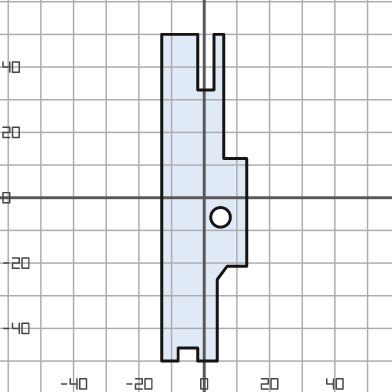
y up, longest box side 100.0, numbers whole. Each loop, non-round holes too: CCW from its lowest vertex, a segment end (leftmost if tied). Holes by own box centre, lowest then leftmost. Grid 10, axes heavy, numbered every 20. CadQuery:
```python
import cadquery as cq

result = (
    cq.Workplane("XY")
    .moveTo(-13.0, -50.0)
    .lineTo(-8.0, -50.0)
    .lineTo(-8.0, -46.0)
    .lineTo(-2.0, -46.0)
    .lineTo(-2.0, -50.0)
    .lineTo(4.0, -50.0)
    .lineTo(4.0, -25.0)
    .lineTo(7.0, -21.0)
    .lineTo(13.0, -21.0)
    .lineTo(13.0, 12.0)
    .lineTo(6.0, 12.0)
    .lineTo(6.0, 50.0)
    .lineTo(3.0, 50.0)
    .lineTo(3.0, 33.0)
    .lineTo(-2.0, 33.0)
    .lineTo(-2.0, 50.0)
    .lineTo(-13.0, 50.0)
    .close()
    .moveTo(5.0, -6.0)
    .circle(3.0)
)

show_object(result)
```